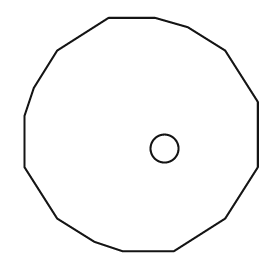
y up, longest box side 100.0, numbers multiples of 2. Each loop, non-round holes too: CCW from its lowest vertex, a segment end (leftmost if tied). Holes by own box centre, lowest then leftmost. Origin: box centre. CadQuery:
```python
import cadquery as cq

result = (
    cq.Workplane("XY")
    .moveTo(-8.0, -50.0)
    .lineTo(14.0, -50.0)
    .lineTo(36.0, -36.0)
    .lineTo(50.0, -14.0)
    .lineTo(50.0, 14.0)
    .lineTo(36.0, 36.0)
    .lineTo(20.0, 46.0)
    .lineTo(6.0, 50.0)
    .lineTo(-14.0, 50.0)
    .lineTo(-36.0, 36.0)
    .lineTo(-46.0, 20.0)
    .lineTo(-50.0, 8.0)
    .lineTo(-50.0, -14.0)
    .lineTo(-36.0, -36.0)
    .lineTo(-20.0, -46.0)
    .close()
    .moveTo(10.0, -6.0)
    .circle(6.0)
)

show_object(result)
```